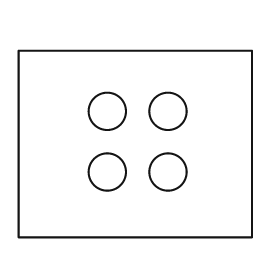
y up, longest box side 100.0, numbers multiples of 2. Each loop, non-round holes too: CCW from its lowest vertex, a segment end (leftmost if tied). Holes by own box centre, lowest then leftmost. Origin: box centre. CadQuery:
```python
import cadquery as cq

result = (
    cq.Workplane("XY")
    .moveTo(-50.0, -40.0)
    .lineTo(50.0, -40.0)
    .lineTo(50.0, 40.0)
    .lineTo(-50.0, 40.0)
    .close()
    .moveTo(-12.0, -12.0)
    .circle(8.0)
    .moveTo(14.0, -12.0)
    .circle(8.0)
    .moveTo(-12.0, 14.0)
    .circle(8.0)
    .moveTo(14.0, 14.0)
    .circle(8.0)
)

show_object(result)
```